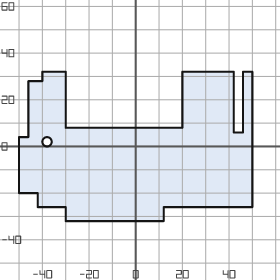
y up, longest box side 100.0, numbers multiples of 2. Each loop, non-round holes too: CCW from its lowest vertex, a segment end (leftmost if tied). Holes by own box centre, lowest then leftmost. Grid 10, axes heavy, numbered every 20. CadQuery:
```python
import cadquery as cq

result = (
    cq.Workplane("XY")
    .moveTo(-30.0, -32.0)
    .lineTo(12.0, -32.0)
    .lineTo(12.0, -26.0)
    .lineTo(50.0, -26.0)
    .lineTo(50.0, 32.0)
    .lineTo(46.0, 32.0)
    .lineTo(46.0, 6.0)
    .lineTo(42.0, 6.0)
    .lineTo(42.0, 32.0)
    .lineTo(20.0, 32.0)
    .lineTo(20.0, 8.0)
    .lineTo(-30.0, 8.0)
    .lineTo(-30.0, 32.0)
    .lineTo(-40.0, 32.0)
    .lineTo(-40.0, 28.0)
    .lineTo(-46.0, 28.0)
    .lineTo(-46.0, 4.0)
    .lineTo(-50.0, 4.0)
    .lineTo(-50.0, -20.0)
    .lineTo(-42.0, -20.0)
    .lineTo(-42.0, -26.0)
    .lineTo(-30.0, -26.0)
    .close()
    .moveTo(-38.0, 2.0)
    .circle(2.0)
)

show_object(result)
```